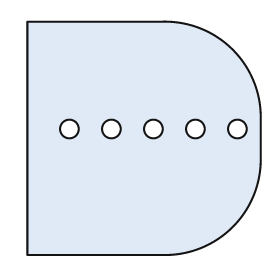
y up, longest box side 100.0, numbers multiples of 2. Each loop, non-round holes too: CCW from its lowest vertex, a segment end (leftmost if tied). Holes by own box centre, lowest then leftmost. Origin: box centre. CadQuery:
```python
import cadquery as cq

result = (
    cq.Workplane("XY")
    .moveTo(-50.0, -50.0)
    .lineTo(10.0, -50.0)
    .threePointArc((38.0, -38.0), (50.0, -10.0))
    .lineTo(50.0, 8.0)
    .threePointArc((38.0, 38.0), (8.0, 50.0))
    .lineTo(-50.0, 50.0)
    .close()
    .moveTo(-32.0, 4.0)
    .circle(4.0)
    .moveTo(-14.0, 4.0)
    .circle(4.0)
    .moveTo(4.0, 4.0)
    .circle(4.0)
    .moveTo(22.0, 4.0)
    .circle(4.0)
    .moveTo(40.0, 4.0)
    .circle(4.0)
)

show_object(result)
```